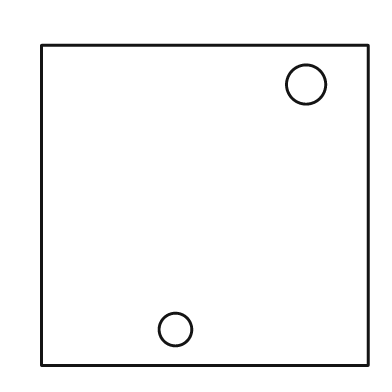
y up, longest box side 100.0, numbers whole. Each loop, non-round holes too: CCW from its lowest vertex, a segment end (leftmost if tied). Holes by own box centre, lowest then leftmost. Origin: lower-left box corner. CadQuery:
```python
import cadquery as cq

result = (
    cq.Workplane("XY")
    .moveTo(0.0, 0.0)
    .lineTo(100.0, 0.0)
    .lineTo(100.0, 98.0)
    .lineTo(0.0, 98.0)
    .close()
    .moveTo(41.0, 11.0)
    .circle(5.0)
    .moveTo(81.0, 86.0)
    .circle(6.0)
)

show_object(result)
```